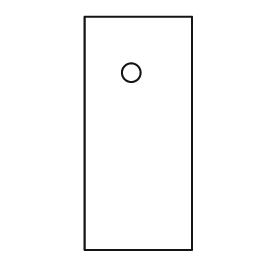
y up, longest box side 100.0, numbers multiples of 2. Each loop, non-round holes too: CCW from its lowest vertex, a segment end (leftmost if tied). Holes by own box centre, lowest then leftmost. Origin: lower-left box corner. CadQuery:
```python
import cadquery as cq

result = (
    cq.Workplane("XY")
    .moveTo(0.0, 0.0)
    .lineTo(46.0, 0.0)
    .lineTo(46.0, 100.0)
    .lineTo(0.0, 100.0)
    .close()
    .moveTo(20.0, 76.0)
    .circle(4.0)
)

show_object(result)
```